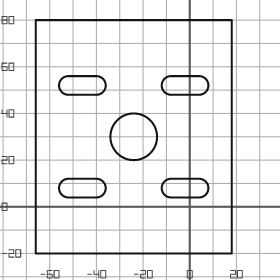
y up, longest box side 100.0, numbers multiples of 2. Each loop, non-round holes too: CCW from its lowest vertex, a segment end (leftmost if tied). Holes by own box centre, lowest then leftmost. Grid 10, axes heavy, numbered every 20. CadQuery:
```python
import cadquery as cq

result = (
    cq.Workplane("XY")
    .moveTo(-66.0, -20.0)
    .lineTo(18.0, -20.0)
    .lineTo(18.0, 80.0)
    .lineTo(-66.0, 80.0)
    .close()
    .moveTo(-52.0, 4.0)
    .lineTo(-40.0, 4.0)
    .threePointArc((-36.0, 8.0), (-40.0, 12.0))
    .lineTo(-52.0, 12.0)
    .threePointArc((-56.0, 8.0), (-52.0, 4.0))
    .close()
    .moveTo(-8.0, 4.0)
    .lineTo(4.0, 4.0)
    .threePointArc((8.0, 8.0), (4.0, 12.0))
    .lineTo(-8.0, 12.0)
    .threePointArc((-12.0, 8.0), (-8.0, 4.0))
    .close()
    .moveTo(-24.0, 30.0)
    .circle(10.0)
    .moveTo(-52.0, 48.0)
    .lineTo(-40.0, 48.0)
    .threePointArc((-36.0, 52.0), (-40.0, 56.0))
    .lineTo(-52.0, 56.0)
    .threePointArc((-56.0, 52.0), (-52.0, 48.0))
    .close()
    .moveTo(-8.0, 48.0)
    .lineTo(4.0, 48.0)
    .threePointArc((8.0, 52.0), (4.0, 56.0))
    .lineTo(-8.0, 56.0)
    .threePointArc((-12.0, 52.0), (-8.0, 48.0))
    .close()
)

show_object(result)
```